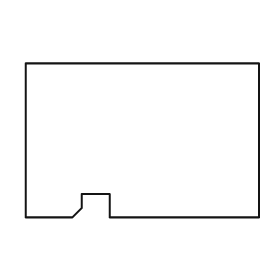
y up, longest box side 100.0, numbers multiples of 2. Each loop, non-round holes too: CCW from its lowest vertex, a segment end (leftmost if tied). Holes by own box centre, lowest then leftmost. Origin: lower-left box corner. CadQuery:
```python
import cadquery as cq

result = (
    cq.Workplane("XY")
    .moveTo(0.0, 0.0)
    .lineTo(20.0, 0.0)
    .lineTo(24.0, 4.0)
    .lineTo(24.0, 10.0)
    .lineTo(36.0, 10.0)
    .lineTo(36.0, 0.0)
    .lineTo(100.0, 0.0)
    .lineTo(100.0, 66.0)
    .lineTo(0.0, 66.0)
    .close()
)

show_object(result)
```